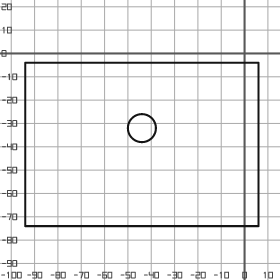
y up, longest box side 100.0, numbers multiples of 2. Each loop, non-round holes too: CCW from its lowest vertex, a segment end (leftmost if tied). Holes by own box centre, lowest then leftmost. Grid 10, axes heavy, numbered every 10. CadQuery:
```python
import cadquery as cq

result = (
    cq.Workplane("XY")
    .moveTo(-94.0, -74.0)
    .lineTo(6.0, -74.0)
    .lineTo(6.0, -4.0)
    .lineTo(-94.0, -4.0)
    .close()
    .moveTo(-44.0, -32.0)
    .circle(6.0)
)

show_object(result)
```